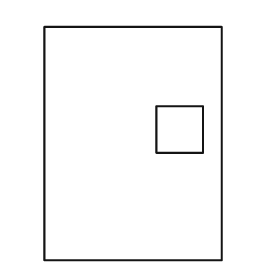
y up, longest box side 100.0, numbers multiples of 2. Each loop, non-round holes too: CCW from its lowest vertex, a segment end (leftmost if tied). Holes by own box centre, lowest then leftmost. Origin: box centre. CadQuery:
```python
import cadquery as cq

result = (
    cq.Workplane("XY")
    .moveTo(-38.0, -50.0)
    .lineTo(38.0, -50.0)
    .lineTo(38.0, 50.0)
    .lineTo(-38.0, 50.0)
    .close()
    .moveTo(10.0, -4.0)
    .lineTo(30.0, -4.0)
    .lineTo(30.0, 16.0)
    .lineTo(10.0, 16.0)
    .close()
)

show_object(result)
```